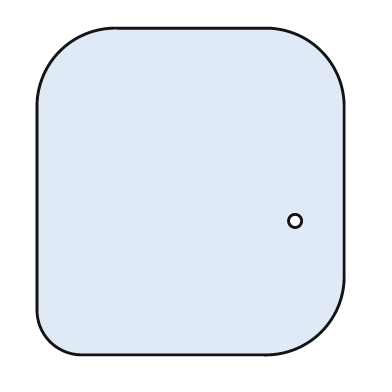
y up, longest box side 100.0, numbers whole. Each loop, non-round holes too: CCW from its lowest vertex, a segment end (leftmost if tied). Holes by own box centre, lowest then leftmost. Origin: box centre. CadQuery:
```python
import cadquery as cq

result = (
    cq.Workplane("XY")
    .moveTo(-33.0, -50.0)
    .lineTo(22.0, -50.0)
    .threePointArc((40.0, -43.0), (47.0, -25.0))
    .lineTo(47.0, 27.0)
    .threePointArc((40.0, 43.0), (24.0, 50.0))
    .lineTo(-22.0, 50.0)
    .threePointArc((-40.0, 43.0), (-47.0, 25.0))
    .lineTo(-47.0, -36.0)
    .threePointArc((-43.0, -46.0), (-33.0, -50.0))
    .close()
    .moveTo(32.0, -9.0)
    .circle(2.0)
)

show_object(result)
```